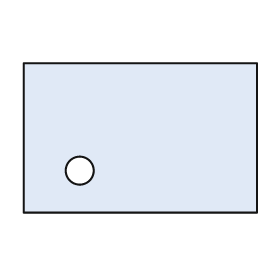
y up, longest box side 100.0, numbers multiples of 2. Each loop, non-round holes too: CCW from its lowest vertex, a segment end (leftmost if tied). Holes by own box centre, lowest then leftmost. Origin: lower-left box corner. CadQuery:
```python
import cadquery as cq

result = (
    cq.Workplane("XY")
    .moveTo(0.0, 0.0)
    .lineTo(100.0, 0.0)
    .lineTo(100.0, 64.0)
    .lineTo(0.0, 64.0)
    .close()
    .moveTo(24.0, 18.0)
    .circle(6.0)
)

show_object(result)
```